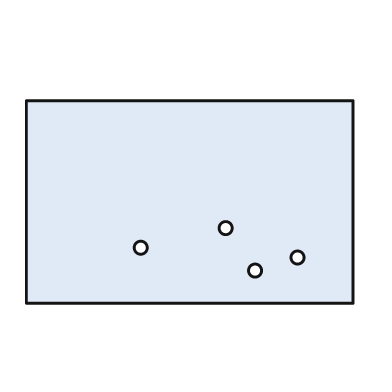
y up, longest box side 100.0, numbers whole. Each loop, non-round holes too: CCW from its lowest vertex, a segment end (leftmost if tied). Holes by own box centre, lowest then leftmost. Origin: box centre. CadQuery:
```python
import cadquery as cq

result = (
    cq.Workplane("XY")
    .moveTo(-50.0, -31.0)
    .lineTo(50.0, -31.0)
    .lineTo(50.0, 31.0)
    .lineTo(-50.0, 31.0)
    .close()
    .moveTo(20.0, -21.0)
    .circle(2.0)
    .moveTo(33.0, -17.0)
    .circle(2.0)
    .moveTo(-15.0, -14.0)
    .circle(2.0)
    .moveTo(11.0, -8.0)
    .circle(2.0)
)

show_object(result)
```